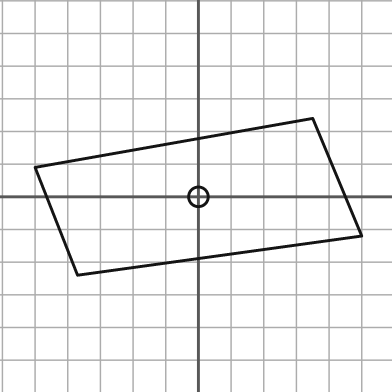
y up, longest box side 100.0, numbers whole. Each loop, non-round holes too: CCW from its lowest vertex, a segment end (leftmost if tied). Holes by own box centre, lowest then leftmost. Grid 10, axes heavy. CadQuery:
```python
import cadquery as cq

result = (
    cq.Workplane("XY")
    .moveTo(-37.0, -24.0)
    .lineTo(50.0, -12.0)
    .lineTo(35.0, 24.0)
    .lineTo(-50.0, 9.0)
    .close()
    .moveTo(0.0, 0.0)
    .circle(3.0)
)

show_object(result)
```